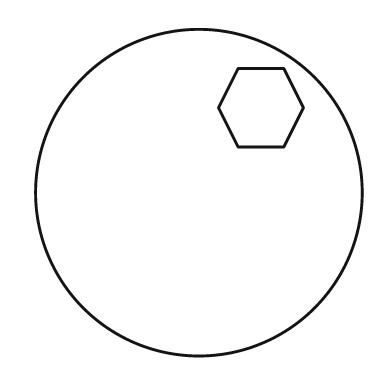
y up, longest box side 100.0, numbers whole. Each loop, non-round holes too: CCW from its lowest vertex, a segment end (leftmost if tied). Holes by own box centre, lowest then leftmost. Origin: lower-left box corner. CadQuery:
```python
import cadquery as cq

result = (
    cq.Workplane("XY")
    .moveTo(50.0, 50.0)
    .circle(50.0)
    .moveTo(62.0, 64.0)
    .lineTo(76.0, 64.0)
    .lineTo(82.0, 76.0)
    .lineTo(76.0, 88.0)
    .lineTo(62.0, 88.0)
    .lineTo(56.0, 76.0)
    .close()
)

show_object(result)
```